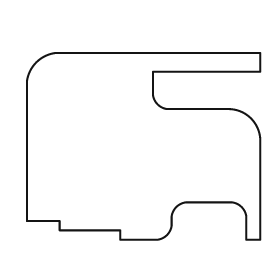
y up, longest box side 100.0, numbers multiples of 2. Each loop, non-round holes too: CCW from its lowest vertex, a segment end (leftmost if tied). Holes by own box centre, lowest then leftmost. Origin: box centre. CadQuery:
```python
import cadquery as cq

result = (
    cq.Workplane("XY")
    .moveTo(-10.0, -40.0)
    .lineTo(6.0, -40.0)
    .threePointArc((10.0, -38.0), (12.0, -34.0))
    .lineTo(12.0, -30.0)
    .threePointArc((14.0, -26.0), (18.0, -24.0))
    .lineTo(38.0, -24.0)
    .threePointArc((42.0, -26.0), (44.0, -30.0))
    .lineTo(44.0, -40.0)
    .lineTo(50.0, -40.0)
    .lineTo(50.0, 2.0)
    .threePointArc((46.0, 12.0), (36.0, 16.0))
    .lineTo(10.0, 16.0)
    .threePointArc((6.0, 18.0), (4.0, 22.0))
    .lineTo(4.0, 32.0)
    .lineTo(50.0, 32.0)
    .lineTo(50.0, 40.0)
    .lineTo(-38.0, 40.0)
    .threePointArc((-46.0, 36.0), (-50.0, 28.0))
    .lineTo(-50.0, -32.0)
    .lineTo(-36.0, -32.0)
    .lineTo(-36.0, -36.0)
    .lineTo(-10.0, -36.0)
    .close()
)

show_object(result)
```